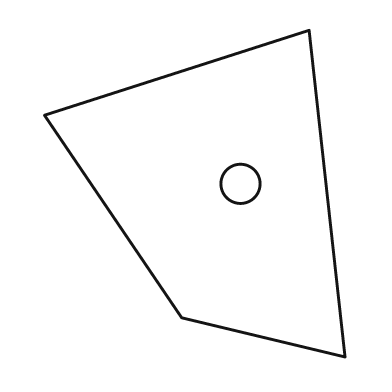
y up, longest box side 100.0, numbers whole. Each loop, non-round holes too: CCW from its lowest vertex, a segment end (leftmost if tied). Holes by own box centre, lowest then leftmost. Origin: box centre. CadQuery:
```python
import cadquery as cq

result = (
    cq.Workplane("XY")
    .moveTo(46.0, -50.0)
    .lineTo(35.0, 50.0)
    .lineTo(-46.0, 24.0)
    .lineTo(-4.0, -38.0)
    .close()
    .moveTo(14.0, 3.0)
    .circle(6.0)
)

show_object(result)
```